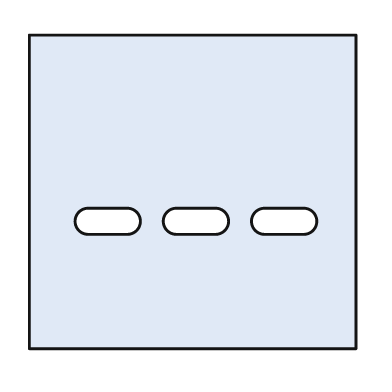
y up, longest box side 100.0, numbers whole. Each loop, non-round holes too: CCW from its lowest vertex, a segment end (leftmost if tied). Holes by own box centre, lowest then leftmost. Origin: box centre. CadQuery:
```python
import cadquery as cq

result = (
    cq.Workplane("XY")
    .moveTo(-50.0, -48.0)
    .lineTo(50.0, -48.0)
    .lineTo(50.0, 48.0)
    .lineTo(-50.0, 48.0)
    .close()
    .moveTo(-32.0, -13.0)
    .lineTo(-20.0, -13.0)
    .threePointArc((-16.0, -9.0), (-20.0, -5.0))
    .lineTo(-32.0, -5.0)
    .threePointArc((-36.0, -9.0), (-32.0, -13.0))
    .close()
    .moveTo(-5.0, -13.0)
    .lineTo(7.0, -13.0)
    .threePointArc((11.0, -9.0), (7.0, -5.0))
    .lineTo(-5.0, -5.0)
    .threePointArc((-9.0, -9.0), (-5.0, -13.0))
    .close()
    .moveTo(22.0, -13.0)
    .lineTo(34.0, -13.0)
    .threePointArc((38.0, -9.0), (34.0, -5.0))
    .lineTo(22.0, -5.0)
    .threePointArc((18.0, -9.0), (22.0, -13.0))
    .close()
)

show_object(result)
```